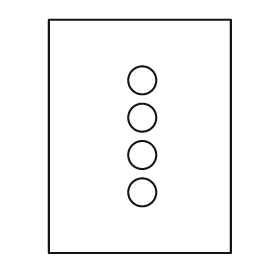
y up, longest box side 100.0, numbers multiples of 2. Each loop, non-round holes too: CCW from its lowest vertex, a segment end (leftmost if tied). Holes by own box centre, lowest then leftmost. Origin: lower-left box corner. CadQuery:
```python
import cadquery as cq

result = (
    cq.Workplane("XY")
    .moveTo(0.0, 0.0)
    .lineTo(78.0, 0.0)
    .lineTo(78.0, 100.0)
    .lineTo(0.0, 100.0)
    .close()
    .moveTo(40.0, 26.0)
    .circle(6.0)
    .moveTo(40.0, 42.0)
    .circle(6.0)
    .moveTo(40.0, 58.0)
    .circle(6.0)
    .moveTo(40.0, 74.0)
    .circle(6.0)
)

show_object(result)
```